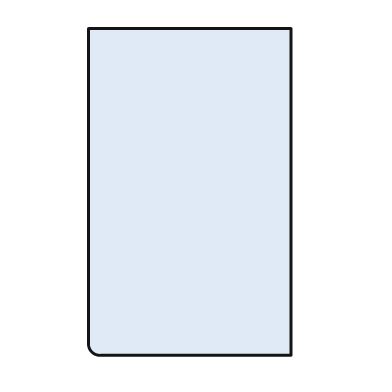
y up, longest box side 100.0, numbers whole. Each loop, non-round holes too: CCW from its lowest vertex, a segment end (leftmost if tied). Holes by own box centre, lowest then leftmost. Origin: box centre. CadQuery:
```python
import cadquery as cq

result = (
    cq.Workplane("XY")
    .moveTo(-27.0, -50.0)
    .lineTo(31.0, -50.0)
    .lineTo(31.0, 50.0)
    .lineTo(-31.0, 50.0)
    .lineTo(-31.0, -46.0)
    .threePointArc((-30.0, -49.0), (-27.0, -50.0))
    .close()
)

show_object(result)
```